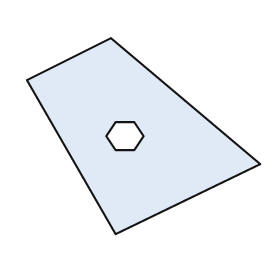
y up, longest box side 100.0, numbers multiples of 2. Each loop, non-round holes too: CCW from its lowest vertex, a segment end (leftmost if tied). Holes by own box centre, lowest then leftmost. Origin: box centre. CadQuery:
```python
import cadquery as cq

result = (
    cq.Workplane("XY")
    .moveTo(-12.0, -42.0)
    .lineTo(50.0, -12.0)
    .lineTo(-14.0, 42.0)
    .lineTo(-50.0, 24.0)
    .close()
    .moveTo(-12.0, -6.0)
    .lineTo(-4.0, -6.0)
    .lineTo(0.0, 0.0)
    .lineTo(-4.0, 6.0)
    .lineTo(-12.0, 6.0)
    .lineTo(-16.0, 0.0)
    .close()
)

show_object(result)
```